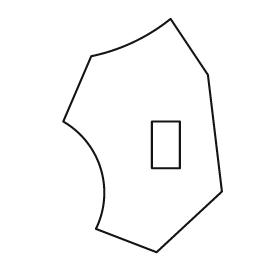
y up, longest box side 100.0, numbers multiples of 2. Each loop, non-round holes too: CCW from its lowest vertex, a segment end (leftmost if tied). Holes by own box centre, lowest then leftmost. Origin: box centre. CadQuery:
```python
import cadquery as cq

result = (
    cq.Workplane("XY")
    .moveTo(6.0, -50.0)
    .lineTo(34.0, -24.0)
    .lineTo(28.0, 26.0)
    .lineTo(12.0, 50.0)
    .threePointArc((-4.0, 40.0), (-22.0, 34.0))
    .lineTo(-34.0, 6.0)
    .threePointArc((-18.0, -14.0), (-20.0, -40.0))
    .close()
    .moveTo(4.0, -14.0)
    .lineTo(16.0, -14.0)
    .lineTo(16.0, 6.0)
    .lineTo(4.0, 6.0)
    .close()
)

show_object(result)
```